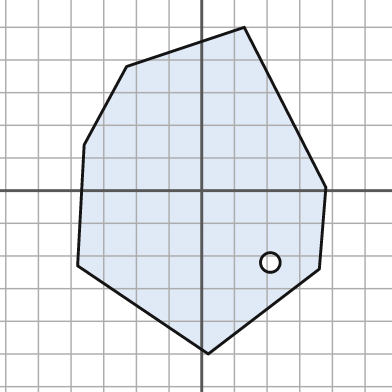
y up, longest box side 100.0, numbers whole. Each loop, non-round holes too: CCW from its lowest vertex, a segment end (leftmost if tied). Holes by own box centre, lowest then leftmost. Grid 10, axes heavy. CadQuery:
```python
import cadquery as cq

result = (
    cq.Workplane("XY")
    .moveTo(2.0, -50.0)
    .lineTo(36.0, -24.0)
    .lineTo(38.0, 1.0)
    .lineTo(13.0, 50.0)
    .lineTo(-23.0, 38.0)
    .lineTo(-36.0, 14.0)
    .lineTo(-38.0, -23.0)
    .close()
    .moveTo(21.0, -22.0)
    .circle(3.0)
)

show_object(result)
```